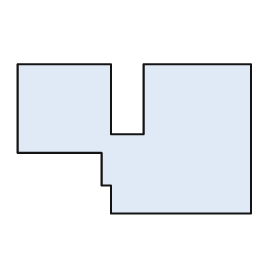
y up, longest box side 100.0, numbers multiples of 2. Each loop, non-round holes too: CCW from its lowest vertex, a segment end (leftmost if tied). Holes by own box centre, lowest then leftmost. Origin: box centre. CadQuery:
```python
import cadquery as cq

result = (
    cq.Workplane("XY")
    .moveTo(-10.0, -32.0)
    .lineTo(50.0, -32.0)
    .lineTo(50.0, 32.0)
    .lineTo(4.0, 32.0)
    .lineTo(4.0, 2.0)
    .lineTo(-10.0, 2.0)
    .lineTo(-10.0, 32.0)
    .lineTo(-50.0, 32.0)
    .lineTo(-50.0, -6.0)
    .lineTo(-14.0, -6.0)
    .lineTo(-14.0, -20.0)
    .lineTo(-10.0, -20.0)
    .close()
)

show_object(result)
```